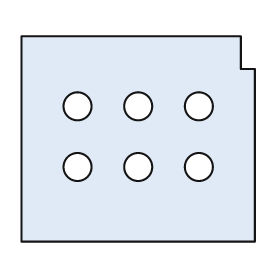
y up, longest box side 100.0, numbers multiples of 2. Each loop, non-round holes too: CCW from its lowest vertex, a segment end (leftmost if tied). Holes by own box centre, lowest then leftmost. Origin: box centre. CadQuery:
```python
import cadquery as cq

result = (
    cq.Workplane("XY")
    .moveTo(-50.0, -44.0)
    .lineTo(50.0, -44.0)
    .lineTo(50.0, 30.0)
    .lineTo(44.0, 30.0)
    .lineTo(44.0, 44.0)
    .lineTo(-50.0, 44.0)
    .close()
    .moveTo(-26.0, -12.0)
    .circle(6.0)
    .moveTo(0.0, -12.0)
    .circle(6.0)
    .moveTo(26.0, -12.0)
    .circle(6.0)
    .moveTo(-26.0, 14.0)
    .circle(6.0)
    .moveTo(0.0, 14.0)
    .circle(6.0)
    .moveTo(26.0, 14.0)
    .circle(6.0)
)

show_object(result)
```